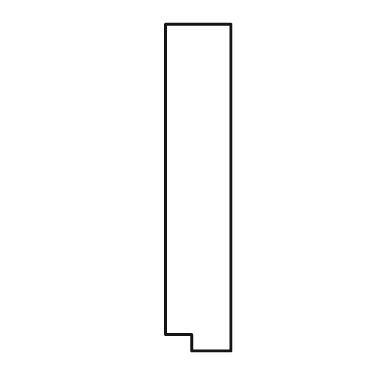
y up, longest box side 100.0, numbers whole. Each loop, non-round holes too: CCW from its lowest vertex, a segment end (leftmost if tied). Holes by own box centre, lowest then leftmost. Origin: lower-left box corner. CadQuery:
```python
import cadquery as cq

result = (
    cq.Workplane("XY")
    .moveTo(8.0, 0.0)
    .lineTo(20.0, 0.0)
    .lineTo(20.0, 100.0)
    .lineTo(0.0, 100.0)
    .lineTo(0.0, 5.0)
    .lineTo(8.0, 5.0)
    .close()
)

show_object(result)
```